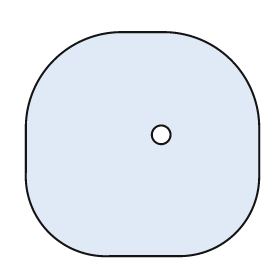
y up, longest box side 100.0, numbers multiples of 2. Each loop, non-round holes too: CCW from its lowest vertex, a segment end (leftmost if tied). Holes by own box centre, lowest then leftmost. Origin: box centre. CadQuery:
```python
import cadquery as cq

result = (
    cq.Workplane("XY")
    .moveTo(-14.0, -48.0)
    .lineTo(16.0, -48.0)
    .threePointArc((40.0, -38.0), (50.0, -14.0))
    .lineTo(50.0, 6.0)
    .threePointArc((38.0, 36.0), (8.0, 48.0))
    .lineTo(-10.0, 48.0)
    .threePointArc((-38.0, 36.0), (-50.0, 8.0))
    .lineTo(-50.0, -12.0)
    .threePointArc((-40.0, -38.0), (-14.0, -48.0))
    .close()
    .moveTo(8.0, 4.0)
    .circle(4.0)
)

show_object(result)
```